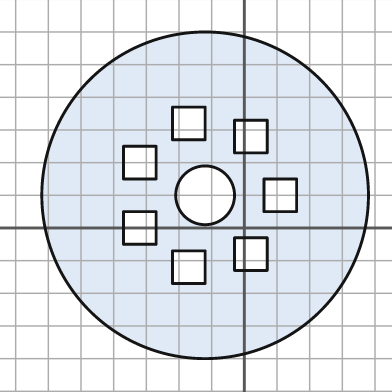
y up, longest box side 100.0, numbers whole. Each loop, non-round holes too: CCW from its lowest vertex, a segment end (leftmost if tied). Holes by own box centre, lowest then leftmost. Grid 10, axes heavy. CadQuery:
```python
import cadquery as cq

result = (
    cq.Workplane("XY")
    .moveTo(-12.0, 10.0)
    .circle(50.0)
    .moveTo(-22.0, -17.0)
    .lineTo(-12.0, -17.0)
    .lineTo(-12.0, -7.0)
    .lineTo(-22.0, -7.0)
    .close()
    .moveTo(-3.0, -13.0)
    .lineTo(7.0, -13.0)
    .lineTo(7.0, -3.0)
    .lineTo(-3.0, -3.0)
    .close()
    .moveTo(-37.0, -5.0)
    .lineTo(-27.0, -5.0)
    .lineTo(-27.0, 5.0)
    .lineTo(-37.0, 5.0)
    .close()
    .moveTo(-12.0, 10.0)
    .circle(9.0)
    .moveTo(6.0, 5.0)
    .lineTo(16.0, 5.0)
    .lineTo(16.0, 15.0)
    .lineTo(6.0, 15.0)
    .close()
    .moveTo(-37.0, 15.0)
    .lineTo(-27.0, 15.0)
    .lineTo(-27.0, 25.0)
    .lineTo(-37.0, 25.0)
    .close()
    .moveTo(-3.0, 23.0)
    .lineTo(7.0, 23.0)
    .lineTo(7.0, 33.0)
    .lineTo(-3.0, 33.0)
    .close()
    .moveTo(-22.0, 27.0)
    .lineTo(-12.0, 27.0)
    .lineTo(-12.0, 37.0)
    .lineTo(-22.0, 37.0)
    .close()
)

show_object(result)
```